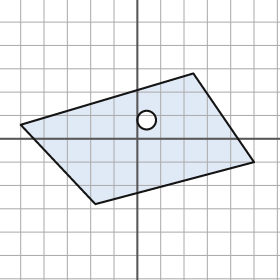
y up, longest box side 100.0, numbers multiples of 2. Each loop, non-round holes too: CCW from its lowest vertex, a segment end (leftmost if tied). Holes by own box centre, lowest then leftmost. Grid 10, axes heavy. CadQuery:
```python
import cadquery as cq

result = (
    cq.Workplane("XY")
    .moveTo(-18.0, -28.0)
    .lineTo(50.0, -10.0)
    .lineTo(24.0, 28.0)
    .lineTo(-50.0, 6.0)
    .close()
    .moveTo(4.0, 8.0)
    .circle(4.0)
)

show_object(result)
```